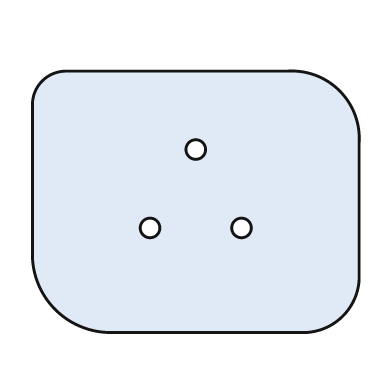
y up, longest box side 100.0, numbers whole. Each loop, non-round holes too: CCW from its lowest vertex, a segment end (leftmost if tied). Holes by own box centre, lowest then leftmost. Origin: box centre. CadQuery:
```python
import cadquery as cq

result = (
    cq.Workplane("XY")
    .moveTo(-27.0, -40.0)
    .lineTo(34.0, -40.0)
    .threePointArc((45.0, -35.0), (50.0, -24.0))
    .lineTo(50.0, 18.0)
    .threePointArc((44.0, 34.0), (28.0, 40.0))
    .lineTo(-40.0, 40.0)
    .threePointArc((-47.0, 37.0), (-50.0, 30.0))
    .lineTo(-50.0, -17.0)
    .threePointArc((-43.0, -33.0), (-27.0, -40.0))
    .close()
    .moveTo(-14.0, -8.0)
    .circle(3.0)
    .moveTo(14.0, -8.0)
    .circle(3.0)
    .moveTo(0.0, 16.0)
    .circle(3.0)
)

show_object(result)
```